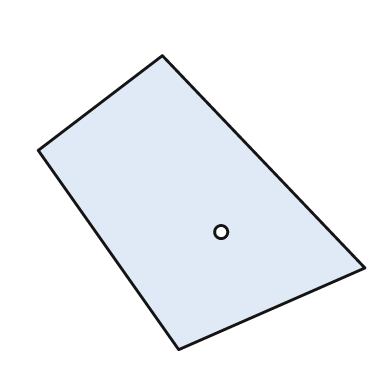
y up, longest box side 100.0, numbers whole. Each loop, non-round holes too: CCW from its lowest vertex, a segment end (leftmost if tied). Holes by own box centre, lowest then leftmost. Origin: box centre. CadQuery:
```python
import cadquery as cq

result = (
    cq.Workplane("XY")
    .moveTo(-7.0, -45.0)
    .lineTo(50.0, -20.0)
    .lineTo(-12.0, 45.0)
    .lineTo(-50.0, 16.0)
    .close()
    .moveTo(6.0, -9.0)
    .circle(2.0)
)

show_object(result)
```